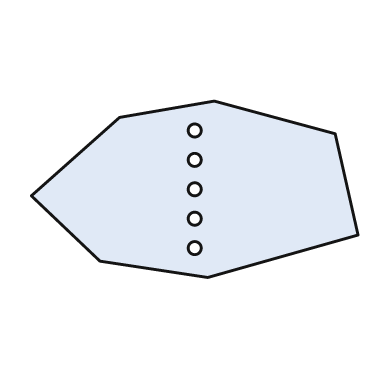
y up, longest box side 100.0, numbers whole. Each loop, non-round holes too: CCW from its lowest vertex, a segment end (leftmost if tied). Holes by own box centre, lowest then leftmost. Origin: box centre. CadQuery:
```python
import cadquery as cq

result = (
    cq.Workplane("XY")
    .moveTo(4.0, -27.0)
    .lineTo(50.0, -14.0)
    .lineTo(43.0, 17.0)
    .lineTo(6.0, 27.0)
    .lineTo(-23.0, 22.0)
    .lineTo(-50.0, -2.0)
    .lineTo(-29.0, -22.0)
    .close()
    .moveTo(0.0, -18.0)
    .circle(2.0)
    .moveTo(0.0, -9.0)
    .circle(2.0)
    .moveTo(0.0, 0.0)
    .circle(2.0)
    .moveTo(0.0, 9.0)
    .circle(2.0)
    .moveTo(0.0, 18.0)
    .circle(2.0)
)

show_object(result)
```